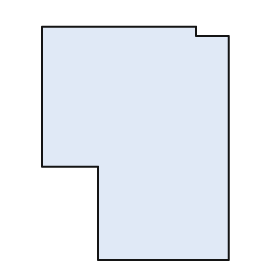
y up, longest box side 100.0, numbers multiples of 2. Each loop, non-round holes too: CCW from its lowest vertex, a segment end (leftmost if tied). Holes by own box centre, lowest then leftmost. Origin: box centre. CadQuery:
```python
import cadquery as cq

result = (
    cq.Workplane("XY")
    .moveTo(-16.0, -50.0)
    .lineTo(40.0, -50.0)
    .lineTo(40.0, 46.0)
    .lineTo(26.0, 46.0)
    .lineTo(26.0, 50.0)
    .lineTo(-40.0, 50.0)
    .lineTo(-40.0, -10.0)
    .lineTo(-16.0, -10.0)
    .close()
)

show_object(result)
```